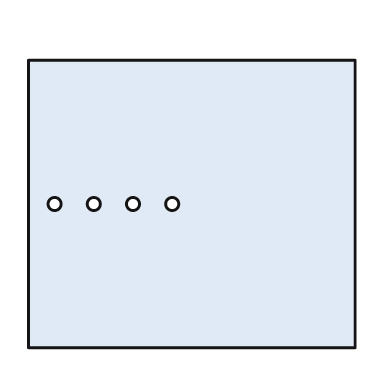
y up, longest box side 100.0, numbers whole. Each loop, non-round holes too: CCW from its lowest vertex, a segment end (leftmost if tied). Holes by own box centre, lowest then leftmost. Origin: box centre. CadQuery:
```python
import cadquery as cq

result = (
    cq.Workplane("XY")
    .moveTo(-50.0, -44.0)
    .lineTo(50.0, -44.0)
    .lineTo(50.0, 44.0)
    .lineTo(-50.0, 44.0)
    .close()
    .moveTo(-42.0, 0.0)
    .circle(2.0)
    .moveTo(-30.0, 0.0)
    .circle(2.0)
    .moveTo(-18.0, 0.0)
    .circle(2.0)
    .moveTo(-6.0, 0.0)
    .circle(2.0)
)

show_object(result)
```